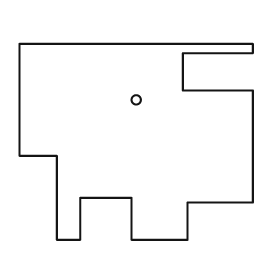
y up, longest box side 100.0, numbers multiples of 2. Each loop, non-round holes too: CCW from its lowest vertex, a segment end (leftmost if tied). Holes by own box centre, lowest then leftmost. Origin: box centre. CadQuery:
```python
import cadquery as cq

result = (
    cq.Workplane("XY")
    .moveTo(-34.0, -42.0)
    .lineTo(-24.0, -42.0)
    .lineTo(-24.0, -24.0)
    .lineTo(-2.0, -24.0)
    .lineTo(-2.0, -42.0)
    .lineTo(22.0, -42.0)
    .lineTo(22.0, -26.0)
    .lineTo(50.0, -26.0)
    .lineTo(50.0, 22.0)
    .lineTo(20.0, 22.0)
    .lineTo(20.0, 38.0)
    .lineTo(50.0, 38.0)
    .lineTo(50.0, 42.0)
    .lineTo(-50.0, 42.0)
    .lineTo(-50.0, -6.0)
    .lineTo(-34.0, -6.0)
    .close()
    .moveTo(0.0, 18.0)
    .circle(2.0)
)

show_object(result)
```